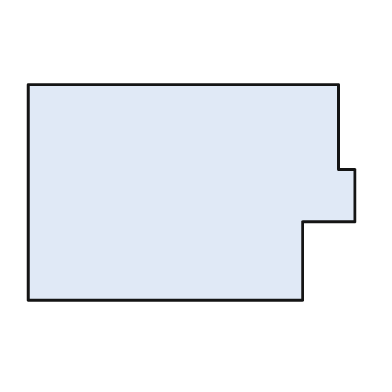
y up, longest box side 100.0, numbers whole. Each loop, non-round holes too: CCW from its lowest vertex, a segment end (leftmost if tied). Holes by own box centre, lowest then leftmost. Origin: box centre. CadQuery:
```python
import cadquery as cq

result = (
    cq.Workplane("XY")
    .moveTo(-50.0, -33.0)
    .lineTo(34.0, -33.0)
    .lineTo(34.0, -9.0)
    .lineTo(50.0, -9.0)
    .lineTo(50.0, 7.0)
    .lineTo(45.0, 7.0)
    .lineTo(45.0, 33.0)
    .lineTo(-50.0, 33.0)
    .close()
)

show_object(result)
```